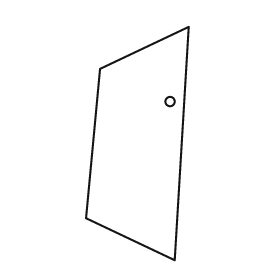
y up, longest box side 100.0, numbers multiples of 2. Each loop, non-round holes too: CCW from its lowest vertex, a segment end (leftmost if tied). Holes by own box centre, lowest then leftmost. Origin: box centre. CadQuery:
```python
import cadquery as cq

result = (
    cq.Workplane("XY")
    .moveTo(16.0, -50.0)
    .lineTo(22.0, 50.0)
    .lineTo(-16.0, 32.0)
    .lineTo(-22.0, -32.0)
    .close()
    .moveTo(14.0, 18.0)
    .circle(2.0)
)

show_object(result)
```